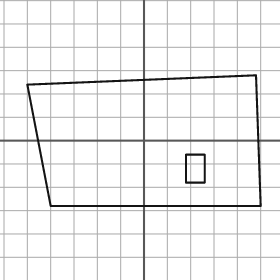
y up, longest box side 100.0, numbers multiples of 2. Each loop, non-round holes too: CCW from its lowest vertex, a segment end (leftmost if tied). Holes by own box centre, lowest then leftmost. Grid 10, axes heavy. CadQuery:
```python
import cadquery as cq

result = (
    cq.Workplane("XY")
    .moveTo(-40.0, -28.0)
    .lineTo(50.0, -28.0)
    .lineTo(48.0, 28.0)
    .lineTo(-50.0, 24.0)
    .close()
    .moveTo(18.0, -18.0)
    .lineTo(26.0, -18.0)
    .lineTo(26.0, -6.0)
    .lineTo(18.0, -6.0)
    .close()
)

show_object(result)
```